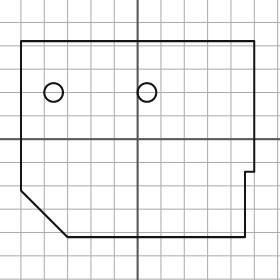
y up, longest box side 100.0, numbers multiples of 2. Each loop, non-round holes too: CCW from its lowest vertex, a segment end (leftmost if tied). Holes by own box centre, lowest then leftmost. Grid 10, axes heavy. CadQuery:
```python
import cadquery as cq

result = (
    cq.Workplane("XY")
    .moveTo(-30.0, -42.0)
    .lineTo(46.0, -42.0)
    .lineTo(46.0, -14.0)
    .lineTo(50.0, -14.0)
    .lineTo(50.0, 42.0)
    .lineTo(-50.0, 42.0)
    .lineTo(-50.0, -22.0)
    .close()
    .moveTo(-36.0, 20.0)
    .circle(4.0)
    .moveTo(4.0, 20.0)
    .circle(4.0)
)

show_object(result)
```